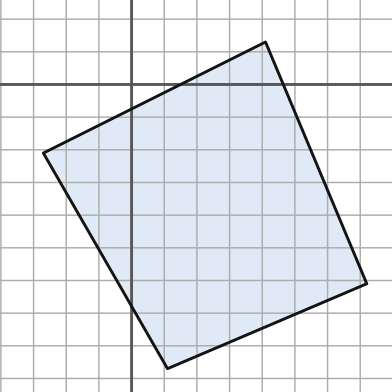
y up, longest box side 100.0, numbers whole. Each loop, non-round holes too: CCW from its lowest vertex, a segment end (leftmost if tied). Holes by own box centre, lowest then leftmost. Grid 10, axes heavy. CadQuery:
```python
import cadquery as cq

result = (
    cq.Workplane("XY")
    .moveTo(11.0, -87.0)
    .lineTo(72.0, -61.0)
    .lineTo(41.0, 13.0)
    .lineTo(-27.0, -21.0)
    .close()
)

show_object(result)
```